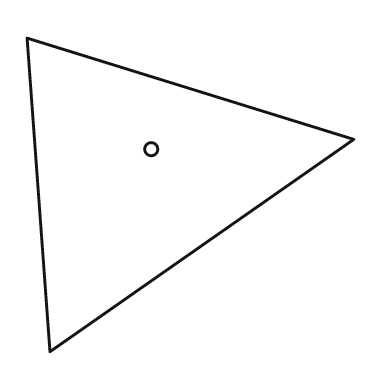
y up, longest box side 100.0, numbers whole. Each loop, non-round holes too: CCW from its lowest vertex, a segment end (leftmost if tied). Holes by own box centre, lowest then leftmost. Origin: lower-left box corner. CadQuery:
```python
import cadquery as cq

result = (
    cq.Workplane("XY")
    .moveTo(7.0, 0.0)
    .lineTo(100.0, 65.0)
    .lineTo(0.0, 96.0)
    .close()
    .moveTo(38.0, 62.0)
    .circle(2.0)
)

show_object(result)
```